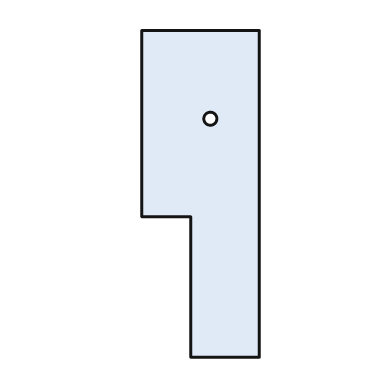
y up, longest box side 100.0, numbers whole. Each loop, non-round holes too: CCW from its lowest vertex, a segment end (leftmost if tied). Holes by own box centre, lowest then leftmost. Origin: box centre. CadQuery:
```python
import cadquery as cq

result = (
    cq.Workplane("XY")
    .moveTo(-3.0, -50.0)
    .lineTo(18.0, -50.0)
    .lineTo(18.0, 50.0)
    .lineTo(-18.0, 50.0)
    .lineTo(-18.0, -7.0)
    .lineTo(-3.0, -7.0)
    .close()
    .moveTo(3.0, 23.0)
    .circle(2.0)
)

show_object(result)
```